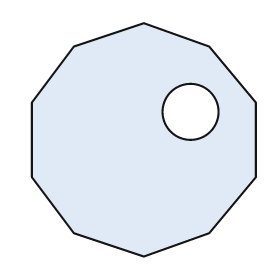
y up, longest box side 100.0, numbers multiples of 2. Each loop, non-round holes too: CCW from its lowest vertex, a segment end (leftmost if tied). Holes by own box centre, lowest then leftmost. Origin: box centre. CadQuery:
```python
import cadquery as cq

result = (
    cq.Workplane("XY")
    .moveTo(0.0, -50.0)
    .lineTo(28.0, -40.0)
    .lineTo(48.0, -16.0)
    .lineTo(48.0, 16.0)
    .lineTo(28.0, 40.0)
    .lineTo(0.0, 50.0)
    .lineTo(-30.0, 40.0)
    .lineTo(-48.0, 16.0)
    .lineTo(-48.0, -16.0)
    .lineTo(-30.0, -40.0)
    .close()
    .moveTo(20.0, 12.0)
    .circle(12.0)
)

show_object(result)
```